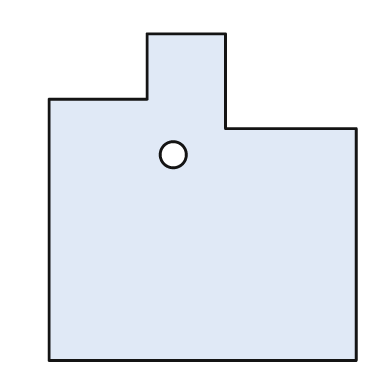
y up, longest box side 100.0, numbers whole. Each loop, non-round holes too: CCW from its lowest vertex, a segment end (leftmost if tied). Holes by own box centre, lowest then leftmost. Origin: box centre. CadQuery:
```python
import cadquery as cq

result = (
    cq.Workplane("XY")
    .moveTo(-47.0, -50.0)
    .lineTo(47.0, -50.0)
    .lineTo(47.0, 21.0)
    .lineTo(7.0, 21.0)
    .lineTo(7.0, 50.0)
    .lineTo(-17.0, 50.0)
    .lineTo(-17.0, 30.0)
    .lineTo(-47.0, 30.0)
    .close()
    .moveTo(-9.0, 13.0)
    .circle(4.0)
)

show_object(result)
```